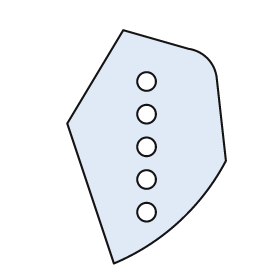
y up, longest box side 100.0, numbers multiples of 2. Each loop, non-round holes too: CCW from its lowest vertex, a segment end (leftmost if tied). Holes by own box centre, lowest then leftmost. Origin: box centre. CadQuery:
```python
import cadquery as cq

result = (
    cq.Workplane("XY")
    .moveTo(-14.0, -50.0)
    .threePointArc((14.0, -32.0), (34.0, -6.0))
    .lineTo(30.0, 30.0)
    .threePointArc((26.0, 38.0), (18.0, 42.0))
    .lineTo(-10.0, 50.0)
    .lineTo(-34.0, 10.0)
    .close()
    .moveTo(0.0, -28.0)
    .circle(4.0)
    .moveTo(0.0, -14.0)
    .circle(4.0)
    .moveTo(0.0, 0.0)
    .circle(4.0)
    .moveTo(0.0, 14.0)
    .circle(4.0)
    .moveTo(0.0, 28.0)
    .circle(4.0)
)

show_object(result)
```